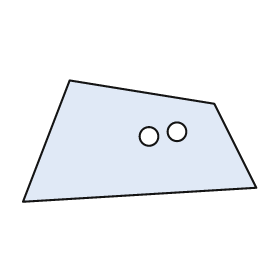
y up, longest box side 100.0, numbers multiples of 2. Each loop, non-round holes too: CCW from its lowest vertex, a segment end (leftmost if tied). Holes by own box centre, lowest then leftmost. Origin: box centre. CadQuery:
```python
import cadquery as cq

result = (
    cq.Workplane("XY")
    .moveTo(-50.0, -26.0)
    .lineTo(50.0, -20.0)
    .lineTo(32.0, 16.0)
    .lineTo(-30.0, 26.0)
    .close()
    .moveTo(4.0, 2.0)
    .circle(4.0)
    .moveTo(16.0, 4.0)
    .circle(4.0)
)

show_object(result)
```